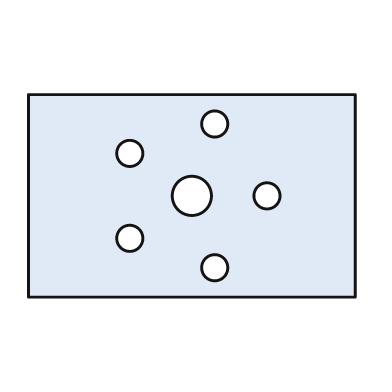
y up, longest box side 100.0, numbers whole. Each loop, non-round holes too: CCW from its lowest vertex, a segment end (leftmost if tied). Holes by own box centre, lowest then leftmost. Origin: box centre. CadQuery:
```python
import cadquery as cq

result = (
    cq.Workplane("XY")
    .moveTo(-50.0, -31.0)
    .lineTo(50.0, -31.0)
    .lineTo(50.0, 31.0)
    .lineTo(-50.0, 31.0)
    .close()
    .moveTo(7.0, -22.0)
    .circle(4.0)
    .moveTo(-19.0, -13.0)
    .circle(4.0)
    .moveTo(0.0, 0.0)
    .circle(6.0)
    .moveTo(23.0, 0.0)
    .circle(4.0)
    .moveTo(-19.0, 13.0)
    .circle(4.0)
    .moveTo(7.0, 22.0)
    .circle(4.0)
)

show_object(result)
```